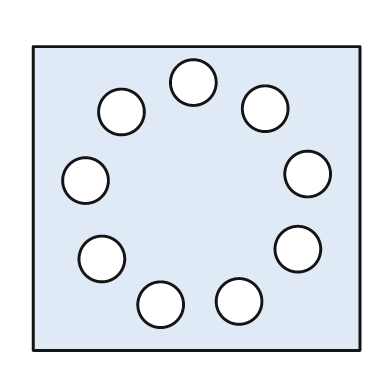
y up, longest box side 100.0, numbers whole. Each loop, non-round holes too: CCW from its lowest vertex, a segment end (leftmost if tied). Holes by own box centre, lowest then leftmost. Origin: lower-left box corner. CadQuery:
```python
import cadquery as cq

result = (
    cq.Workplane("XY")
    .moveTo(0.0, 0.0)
    .lineTo(100.0, 0.0)
    .lineTo(100.0, 93.0)
    .lineTo(0.0, 93.0)
    .close()
    .moveTo(39.0, 14.0)
    .circle(7.0)
    .moveTo(63.0, 15.0)
    .circle(7.0)
    .moveTo(21.0, 28.0)
    .circle(7.0)
    .moveTo(81.0, 31.0)
    .circle(7.0)
    .moveTo(16.0, 52.0)
    .circle(7.0)
    .moveTo(84.0, 54.0)
    .circle(7.0)
    .moveTo(27.0, 73.0)
    .circle(7.0)
    .moveTo(71.0, 74.0)
    .circle(7.0)
    .moveTo(49.0, 82.0)
    .circle(7.0)
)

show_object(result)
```